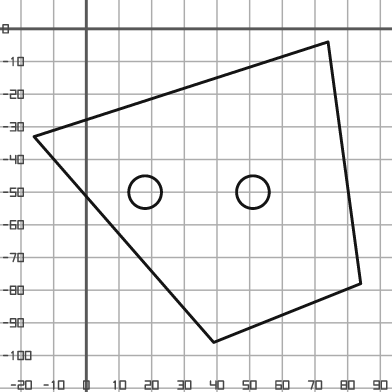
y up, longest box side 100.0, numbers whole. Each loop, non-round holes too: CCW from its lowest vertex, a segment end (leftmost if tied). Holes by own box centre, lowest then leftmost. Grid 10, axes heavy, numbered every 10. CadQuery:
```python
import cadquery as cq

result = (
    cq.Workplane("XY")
    .moveTo(39.0, -96.0)
    .lineTo(84.0, -78.0)
    .lineTo(74.0, -4.0)
    .lineTo(-16.0, -33.0)
    .close()
    .moveTo(18.0, -50.0)
    .circle(5.0)
    .moveTo(51.0, -50.0)
    .circle(5.0)
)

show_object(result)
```